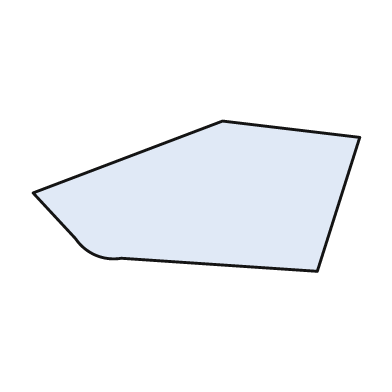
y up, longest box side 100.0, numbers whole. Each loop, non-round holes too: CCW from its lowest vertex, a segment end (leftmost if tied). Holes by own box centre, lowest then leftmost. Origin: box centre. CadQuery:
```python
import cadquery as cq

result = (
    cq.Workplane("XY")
    .moveTo(37.0, -23.0)
    .lineTo(50.0, 18.0)
    .lineTo(8.0, 23.0)
    .lineTo(-50.0, 1.0)
    .lineTo(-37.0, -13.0)
    .threePointArc((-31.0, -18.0), (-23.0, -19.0))
    .close()
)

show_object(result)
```